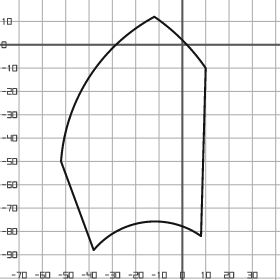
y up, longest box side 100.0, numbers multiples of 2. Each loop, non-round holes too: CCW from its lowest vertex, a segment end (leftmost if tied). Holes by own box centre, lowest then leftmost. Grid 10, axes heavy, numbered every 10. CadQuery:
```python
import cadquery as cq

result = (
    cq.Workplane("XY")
    .moveTo(-38.0, -88.0)
    .threePointArc((-16.0, -76.0), (8.0, -82.0))
    .lineTo(10.0, -10.0)
    .threePointArc((0.0, 2.0), (-12.0, 12.0))
    .threePointArc((-40.0, -14.0), (-52.0, -50.0))
    .close()
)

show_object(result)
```